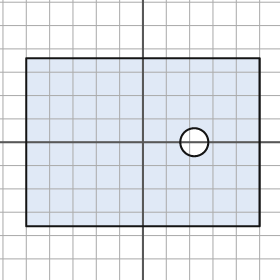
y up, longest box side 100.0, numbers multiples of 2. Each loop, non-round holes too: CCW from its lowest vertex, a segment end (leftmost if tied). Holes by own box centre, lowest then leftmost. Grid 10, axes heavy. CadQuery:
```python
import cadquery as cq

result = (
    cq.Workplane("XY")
    .moveTo(-50.0, -36.0)
    .lineTo(50.0, -36.0)
    .lineTo(50.0, 36.0)
    .lineTo(-50.0, 36.0)
    .close()
    .moveTo(22.0, 0.0)
    .circle(6.0)
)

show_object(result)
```